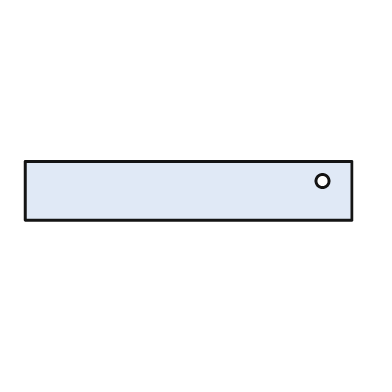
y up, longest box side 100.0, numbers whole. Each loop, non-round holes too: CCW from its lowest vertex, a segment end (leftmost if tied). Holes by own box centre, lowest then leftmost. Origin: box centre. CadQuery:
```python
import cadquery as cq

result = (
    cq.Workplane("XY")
    .moveTo(-50.0, -9.0)
    .lineTo(50.0, -9.0)
    .lineTo(50.0, 9.0)
    .lineTo(-50.0, 9.0)
    .close()
    .moveTo(41.0, 3.0)
    .circle(2.0)
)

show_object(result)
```